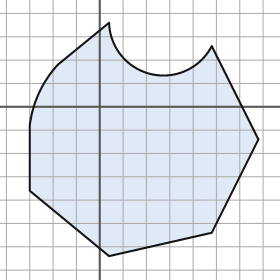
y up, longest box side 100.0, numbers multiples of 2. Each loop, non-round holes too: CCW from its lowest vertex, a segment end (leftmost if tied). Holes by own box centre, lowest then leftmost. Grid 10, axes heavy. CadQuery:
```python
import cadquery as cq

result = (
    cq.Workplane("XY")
    .moveTo(4.0, -64.0)
    .lineTo(48.0, -54.0)
    .lineTo(68.0, -14.0)
    .lineTo(48.0, 26.0)
    .threePointArc((22.0, 14.0), (4.0, 36.0))
    .lineTo(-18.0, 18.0)
    .threePointArc((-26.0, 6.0), (-30.0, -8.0))
    .lineTo(-30.0, -36.0)
    .close()
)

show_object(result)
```